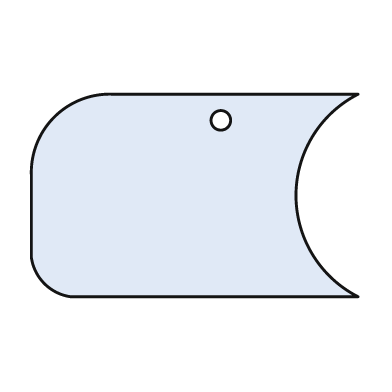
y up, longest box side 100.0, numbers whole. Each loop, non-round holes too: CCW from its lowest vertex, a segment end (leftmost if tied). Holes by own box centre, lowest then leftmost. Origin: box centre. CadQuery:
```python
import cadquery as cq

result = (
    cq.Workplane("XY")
    .moveTo(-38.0, -31.0)
    .lineTo(50.0, -31.0)
    .threePointArc((31.0, 0.0), (50.0, 31.0))
    .lineTo(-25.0, 31.0)
    .threePointArc((-43.0, 24.0), (-50.0, 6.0))
    .lineTo(-50.0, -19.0)
    .threePointArc((-46.0, -27.0), (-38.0, -31.0))
    .close()
    .moveTo(8.0, 23.0)
    .circle(3.0)
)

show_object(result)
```